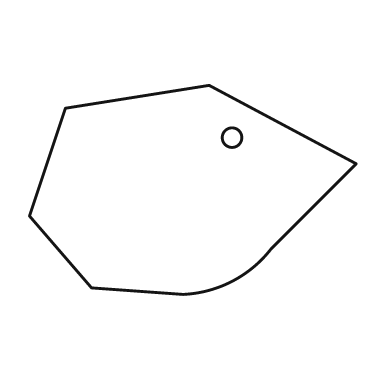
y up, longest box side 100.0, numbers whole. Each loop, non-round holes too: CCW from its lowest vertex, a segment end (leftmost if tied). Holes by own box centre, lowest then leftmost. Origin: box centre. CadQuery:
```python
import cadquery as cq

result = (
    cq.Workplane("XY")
    .moveTo(-3.0, -32.0)
    .threePointArc((12.0, -28.0), (24.0, -18.0))
    .lineTo(50.0, 8.0)
    .lineTo(5.0, 32.0)
    .lineTo(-39.0, 25.0)
    .lineTo(-50.0, -8.0)
    .lineTo(-31.0, -30.0)
    .close()
    .moveTo(12.0, 16.0)
    .circle(3.0)
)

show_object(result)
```